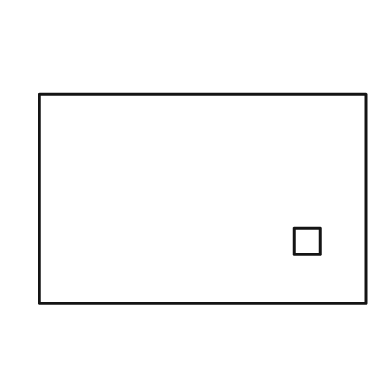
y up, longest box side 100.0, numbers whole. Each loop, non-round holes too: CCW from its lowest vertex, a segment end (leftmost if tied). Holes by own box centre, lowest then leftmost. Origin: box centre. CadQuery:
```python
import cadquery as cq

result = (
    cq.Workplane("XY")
    .moveTo(-50.0, -32.0)
    .lineTo(50.0, -32.0)
    .lineTo(50.0, 32.0)
    .lineTo(-50.0, 32.0)
    .close()
    .moveTo(28.0, -17.0)
    .lineTo(36.0, -17.0)
    .lineTo(36.0, -9.0)
    .lineTo(28.0, -9.0)
    .close()
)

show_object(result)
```